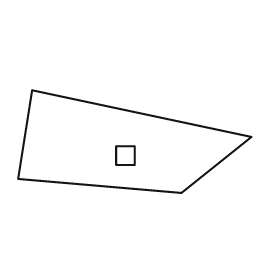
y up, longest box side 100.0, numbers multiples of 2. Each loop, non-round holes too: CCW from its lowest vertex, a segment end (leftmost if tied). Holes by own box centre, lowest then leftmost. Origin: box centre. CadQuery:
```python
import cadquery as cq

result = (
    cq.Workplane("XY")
    .moveTo(20.0, -22.0)
    .lineTo(50.0, 2.0)
    .lineTo(-44.0, 22.0)
    .lineTo(-50.0, -16.0)
    .close()
    .moveTo(-8.0, -10.0)
    .lineTo(0.0, -10.0)
    .lineTo(0.0, -2.0)
    .lineTo(-8.0, -2.0)
    .close()
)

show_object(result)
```